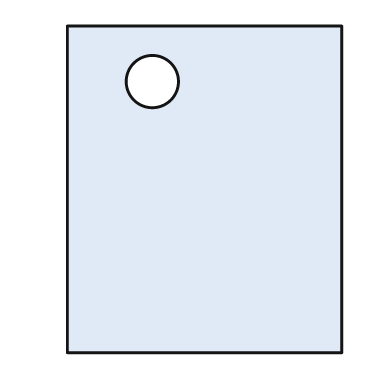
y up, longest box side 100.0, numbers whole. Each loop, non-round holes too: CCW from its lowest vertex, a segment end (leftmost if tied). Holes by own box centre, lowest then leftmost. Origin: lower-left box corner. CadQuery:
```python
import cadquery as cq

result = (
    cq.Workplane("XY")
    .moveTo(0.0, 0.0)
    .lineTo(84.0, 0.0)
    .lineTo(84.0, 100.0)
    .lineTo(0.0, 100.0)
    .close()
    .moveTo(26.0, 83.0)
    .circle(8.0)
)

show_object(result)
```